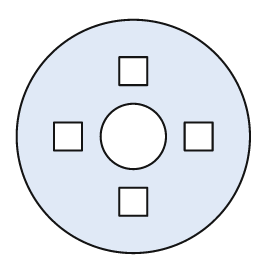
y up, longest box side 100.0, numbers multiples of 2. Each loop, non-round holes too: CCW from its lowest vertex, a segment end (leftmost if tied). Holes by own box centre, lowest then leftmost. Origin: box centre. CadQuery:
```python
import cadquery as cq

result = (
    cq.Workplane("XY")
    .moveTo(0.0, 0.0)
    .circle(50.0)
    .moveTo(-6.0, -34.0)
    .lineTo(6.0, -34.0)
    .lineTo(6.0, -22.0)
    .lineTo(-6.0, -22.0)
    .close()
    .moveTo(-34.0, -6.0)
    .lineTo(-22.0, -6.0)
    .lineTo(-22.0, 6.0)
    .lineTo(-34.0, 6.0)
    .close()
    .moveTo(0.0, 0.0)
    .circle(14.0)
    .moveTo(22.0, -6.0)
    .lineTo(34.0, -6.0)
    .lineTo(34.0, 6.0)
    .lineTo(22.0, 6.0)
    .close()
    .moveTo(-6.0, 22.0)
    .lineTo(6.0, 22.0)
    .lineTo(6.0, 34.0)
    .lineTo(-6.0, 34.0)
    .close()
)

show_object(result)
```